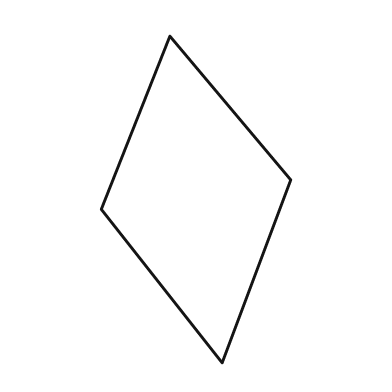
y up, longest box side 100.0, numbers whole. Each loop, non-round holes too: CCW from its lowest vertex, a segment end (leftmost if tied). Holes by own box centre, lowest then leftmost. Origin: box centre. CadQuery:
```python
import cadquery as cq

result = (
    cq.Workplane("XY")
    .moveTo(8.0, -50.0)
    .lineTo(29.0, 6.0)
    .lineTo(-8.0, 50.0)
    .lineTo(-29.0, -3.0)
    .close()
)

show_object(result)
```